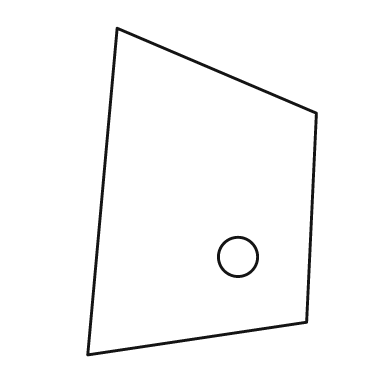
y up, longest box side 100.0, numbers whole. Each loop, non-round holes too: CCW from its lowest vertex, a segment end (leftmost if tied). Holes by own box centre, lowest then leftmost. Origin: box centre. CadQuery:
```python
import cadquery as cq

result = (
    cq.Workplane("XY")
    .moveTo(-35.0, -50.0)
    .lineTo(32.0, -40.0)
    .lineTo(35.0, 24.0)
    .lineTo(-26.0, 50.0)
    .close()
    .moveTo(11.0, -20.0)
    .circle(6.0)
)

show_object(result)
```